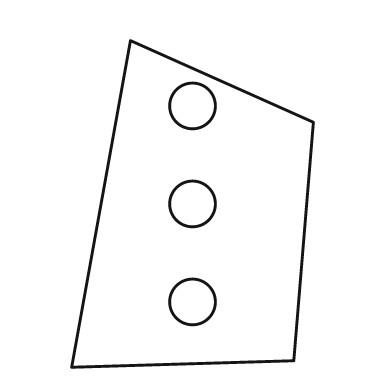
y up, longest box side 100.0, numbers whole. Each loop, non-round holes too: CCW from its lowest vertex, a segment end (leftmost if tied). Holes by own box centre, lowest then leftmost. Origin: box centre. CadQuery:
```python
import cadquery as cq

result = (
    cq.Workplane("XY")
    .moveTo(-37.0, -50.0)
    .lineTo(31.0, -48.0)
    .lineTo(37.0, 25.0)
    .lineTo(-19.0, 50.0)
    .close()
    .moveTo(0.0, -30.0)
    .circle(7.0)
    .moveTo(0.0, 0.0)
    .circle(7.0)
    .moveTo(0.0, 30.0)
    .circle(7.0)
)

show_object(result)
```